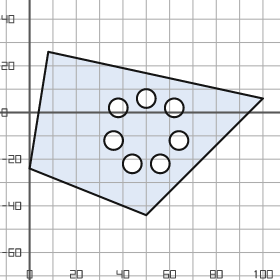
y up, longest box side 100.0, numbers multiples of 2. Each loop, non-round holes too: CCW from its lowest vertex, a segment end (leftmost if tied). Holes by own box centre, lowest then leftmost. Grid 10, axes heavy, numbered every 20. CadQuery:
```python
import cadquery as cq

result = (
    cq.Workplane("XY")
    .moveTo(50.0, -44.0)
    .lineTo(100.0, 6.0)
    .lineTo(8.0, 26.0)
    .lineTo(0.0, -24.0)
    .close()
    .moveTo(44.0, -22.0)
    .circle(4.0)
    .moveTo(56.0, -22.0)
    .circle(4.0)
    .moveTo(36.0, -12.0)
    .circle(4.0)
    .moveTo(64.0, -12.0)
    .circle(4.0)
    .moveTo(38.0, 2.0)
    .circle(4.0)
    .moveTo(62.0, 2.0)
    .circle(4.0)
    .moveTo(50.0, 6.0)
    .circle(4.0)
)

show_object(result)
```